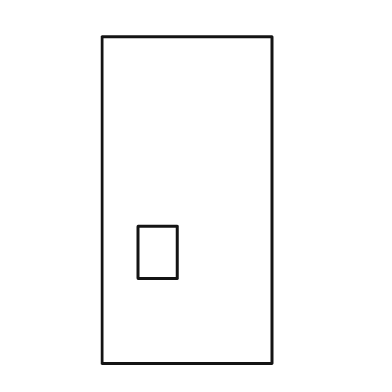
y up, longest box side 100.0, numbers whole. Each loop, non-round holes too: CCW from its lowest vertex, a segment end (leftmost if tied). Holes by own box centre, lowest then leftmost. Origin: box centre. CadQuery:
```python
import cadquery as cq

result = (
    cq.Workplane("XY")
    .moveTo(-26.0, -50.0)
    .lineTo(26.0, -50.0)
    .lineTo(26.0, 50.0)
    .lineTo(-26.0, 50.0)
    .close()
    .moveTo(-15.0, -24.0)
    .lineTo(-3.0, -24.0)
    .lineTo(-3.0, -8.0)
    .lineTo(-15.0, -8.0)
    .close()
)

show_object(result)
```